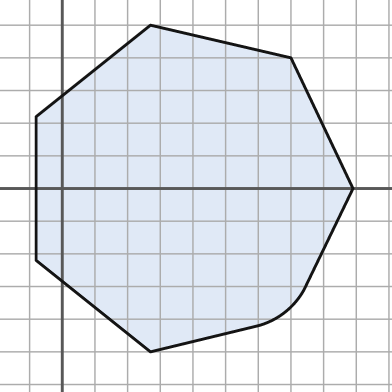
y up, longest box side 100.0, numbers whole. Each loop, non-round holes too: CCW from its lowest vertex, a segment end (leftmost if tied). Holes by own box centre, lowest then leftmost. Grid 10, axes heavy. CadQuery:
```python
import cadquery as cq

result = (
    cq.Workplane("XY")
    .moveTo(27.0, -50.0)
    .lineTo(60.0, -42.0)
    .threePointArc((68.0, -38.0), (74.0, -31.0))
    .lineTo(89.0, 0.0)
    .lineTo(70.0, 40.0)
    .lineTo(27.0, 50.0)
    .lineTo(-8.0, 22.0)
    .lineTo(-8.0, -22.0)
    .close()
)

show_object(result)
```